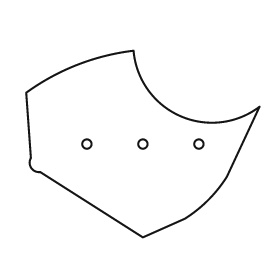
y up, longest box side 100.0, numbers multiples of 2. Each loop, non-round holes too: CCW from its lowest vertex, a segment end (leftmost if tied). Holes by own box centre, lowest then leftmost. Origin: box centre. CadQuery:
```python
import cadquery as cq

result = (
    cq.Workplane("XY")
    .moveTo(0.0, -40.0)
    .lineTo(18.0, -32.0)
    .threePointArc((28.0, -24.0), (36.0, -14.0))
    .lineTo(50.0, 16.0)
    .threePointArc((16.0, 12.0), (-4.0, 40.0))
    .threePointArc((-28.0, 34.0), (-50.0, 22.0))
    .lineTo(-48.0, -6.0)
    .threePointArc((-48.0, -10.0), (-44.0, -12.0))
    .close()
    .moveTo(-24.0, 0.0)
    .circle(2.0)
    .moveTo(0.0, 0.0)
    .circle(2.0)
    .moveTo(24.0, 0.0)
    .circle(2.0)
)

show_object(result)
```